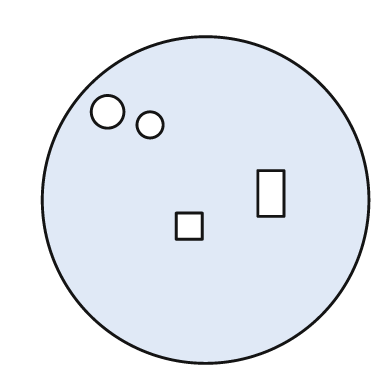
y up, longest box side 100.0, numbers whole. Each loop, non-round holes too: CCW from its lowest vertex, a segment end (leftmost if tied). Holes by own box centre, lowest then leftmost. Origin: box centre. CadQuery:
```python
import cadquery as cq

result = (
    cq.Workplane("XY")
    .moveTo(0.0, 0.0)
    .circle(50.0)
    .moveTo(-9.0, -12.0)
    .lineTo(-1.0, -12.0)
    .lineTo(-1.0, -4.0)
    .lineTo(-9.0, -4.0)
    .close()
    .moveTo(16.0, -5.0)
    .lineTo(24.0, -5.0)
    .lineTo(24.0, 9.0)
    .lineTo(16.0, 9.0)
    .close()
    .moveTo(-17.0, 23.0)
    .circle(4.0)
    .moveTo(-30.0, 27.0)
    .circle(5.0)
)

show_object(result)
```